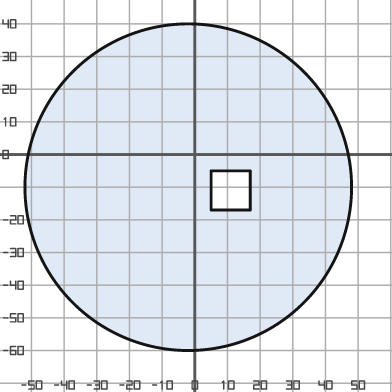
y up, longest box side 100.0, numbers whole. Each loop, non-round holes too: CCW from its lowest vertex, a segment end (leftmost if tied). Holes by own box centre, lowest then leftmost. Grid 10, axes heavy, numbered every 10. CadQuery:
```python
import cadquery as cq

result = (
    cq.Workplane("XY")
    .moveTo(-2.0, -10.0)
    .circle(50.0)
    .moveTo(5.0, -17.0)
    .lineTo(17.0, -17.0)
    .lineTo(17.0, -5.0)
    .lineTo(5.0, -5.0)
    .close()
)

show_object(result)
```